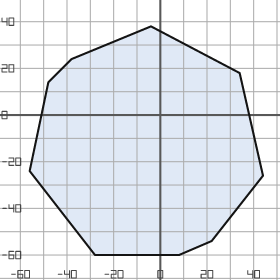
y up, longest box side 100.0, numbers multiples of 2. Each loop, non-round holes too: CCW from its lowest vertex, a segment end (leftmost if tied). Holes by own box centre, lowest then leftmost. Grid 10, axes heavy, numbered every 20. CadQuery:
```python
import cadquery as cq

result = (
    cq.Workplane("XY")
    .moveTo(-28.0, -60.0)
    .lineTo(8.0, -60.0)
    .lineTo(22.0, -54.0)
    .lineTo(44.0, -26.0)
    .lineTo(34.0, 18.0)
    .lineTo(-4.0, 38.0)
    .lineTo(-38.0, 24.0)
    .lineTo(-48.0, 14.0)
    .lineTo(-56.0, -24.0)
    .close()
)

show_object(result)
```